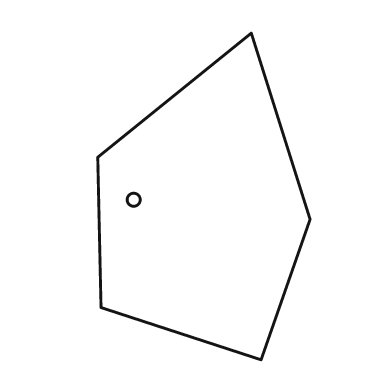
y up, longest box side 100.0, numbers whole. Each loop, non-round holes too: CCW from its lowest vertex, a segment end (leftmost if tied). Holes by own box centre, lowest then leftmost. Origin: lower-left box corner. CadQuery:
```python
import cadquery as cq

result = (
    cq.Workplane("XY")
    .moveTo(50.0, 0.0)
    .lineTo(65.0, 43.0)
    .lineTo(47.0, 100.0)
    .lineTo(0.0, 62.0)
    .lineTo(1.0, 16.0)
    .close()
    .moveTo(11.0, 49.0)
    .circle(2.0)
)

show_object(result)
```